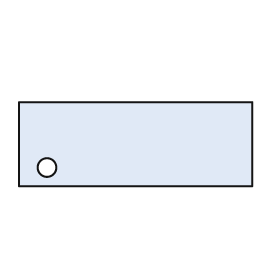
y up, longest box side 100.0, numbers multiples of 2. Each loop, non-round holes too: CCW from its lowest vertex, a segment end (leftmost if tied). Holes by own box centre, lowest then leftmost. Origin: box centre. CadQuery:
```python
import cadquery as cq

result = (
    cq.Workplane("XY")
    .moveTo(-50.0, -18.0)
    .lineTo(50.0, -18.0)
    .lineTo(50.0, 18.0)
    .lineTo(-50.0, 18.0)
    .close()
    .moveTo(-38.0, -10.0)
    .circle(4.0)
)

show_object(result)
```